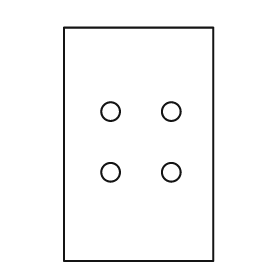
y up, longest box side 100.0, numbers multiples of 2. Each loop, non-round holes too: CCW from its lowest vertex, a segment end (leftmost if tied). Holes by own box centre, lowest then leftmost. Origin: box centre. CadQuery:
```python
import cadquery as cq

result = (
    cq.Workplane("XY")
    .moveTo(-32.0, -50.0)
    .lineTo(32.0, -50.0)
    .lineTo(32.0, 50.0)
    .lineTo(-32.0, 50.0)
    .close()
    .moveTo(-12.0, -12.0)
    .circle(4.0)
    .moveTo(14.0, -12.0)
    .circle(4.0)
    .moveTo(-12.0, 14.0)
    .circle(4.0)
    .moveTo(14.0, 14.0)
    .circle(4.0)
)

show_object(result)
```